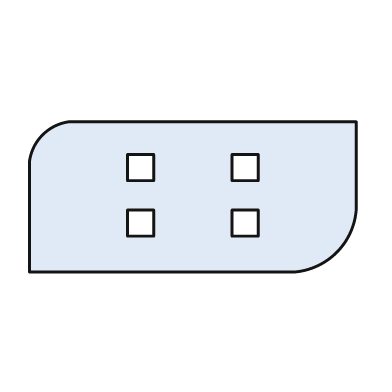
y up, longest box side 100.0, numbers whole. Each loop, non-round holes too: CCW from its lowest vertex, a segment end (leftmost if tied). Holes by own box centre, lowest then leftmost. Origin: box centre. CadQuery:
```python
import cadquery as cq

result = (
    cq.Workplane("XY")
    .moveTo(-50.0, -23.0)
    .lineTo(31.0, -23.0)
    .threePointArc((44.0, -17.0), (50.0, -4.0))
    .lineTo(50.0, 23.0)
    .lineTo(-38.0, 23.0)
    .threePointArc((-46.0, 19.0), (-50.0, 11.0))
    .close()
    .moveTo(-20.0, -12.0)
    .lineTo(-12.0, -12.0)
    .lineTo(-12.0, -4.0)
    .lineTo(-20.0, -4.0)
    .close()
    .moveTo(12.0, -12.0)
    .lineTo(20.0, -12.0)
    .lineTo(20.0, -4.0)
    .lineTo(12.0, -4.0)
    .close()
    .moveTo(-20.0, 5.0)
    .lineTo(-12.0, 5.0)
    .lineTo(-12.0, 13.0)
    .lineTo(-20.0, 13.0)
    .close()
    .moveTo(12.0, 5.0)
    .lineTo(20.0, 5.0)
    .lineTo(20.0, 13.0)
    .lineTo(12.0, 13.0)
    .close()
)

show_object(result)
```